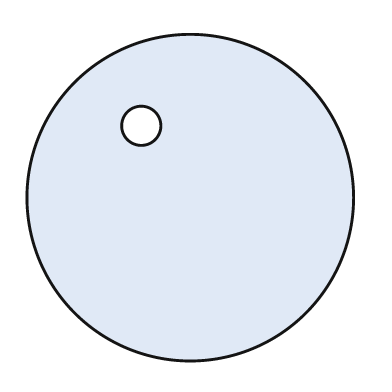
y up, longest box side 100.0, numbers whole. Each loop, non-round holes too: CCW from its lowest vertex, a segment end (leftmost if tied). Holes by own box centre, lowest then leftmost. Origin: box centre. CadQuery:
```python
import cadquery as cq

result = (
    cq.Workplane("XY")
    .moveTo(0.0, 0.0)
    .circle(50.0)
    .moveTo(-15.0, 22.0)
    .circle(6.0)
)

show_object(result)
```